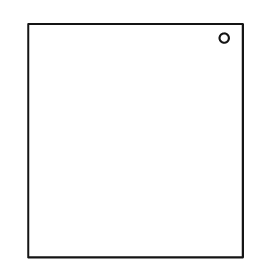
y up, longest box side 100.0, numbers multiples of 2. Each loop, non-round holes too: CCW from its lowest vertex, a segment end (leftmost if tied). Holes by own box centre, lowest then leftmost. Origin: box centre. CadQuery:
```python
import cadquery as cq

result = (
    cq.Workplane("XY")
    .moveTo(-46.0, -50.0)
    .lineTo(46.0, -50.0)
    .lineTo(46.0, 50.0)
    .lineTo(-46.0, 50.0)
    .close()
    .moveTo(38.0, 44.0)
    .circle(2.0)
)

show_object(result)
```